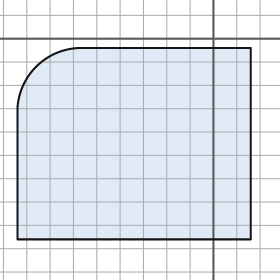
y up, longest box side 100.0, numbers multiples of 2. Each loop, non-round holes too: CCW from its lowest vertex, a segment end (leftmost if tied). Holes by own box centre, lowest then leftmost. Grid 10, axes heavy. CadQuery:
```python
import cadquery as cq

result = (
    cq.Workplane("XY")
    .moveTo(-84.0, -86.0)
    .lineTo(16.0, -86.0)
    .lineTo(16.0, -4.0)
    .lineTo(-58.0, -4.0)
    .threePointArc((-76.0, -12.0), (-84.0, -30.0))
    .close()
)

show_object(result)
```